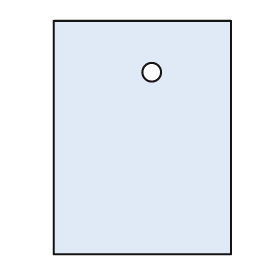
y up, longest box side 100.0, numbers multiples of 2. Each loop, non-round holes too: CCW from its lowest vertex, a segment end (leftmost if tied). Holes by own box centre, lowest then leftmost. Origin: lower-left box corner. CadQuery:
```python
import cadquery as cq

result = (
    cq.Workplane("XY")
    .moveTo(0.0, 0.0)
    .lineTo(76.0, 0.0)
    .lineTo(76.0, 100.0)
    .lineTo(0.0, 100.0)
    .close()
    .moveTo(42.0, 78.0)
    .circle(4.0)
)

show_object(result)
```